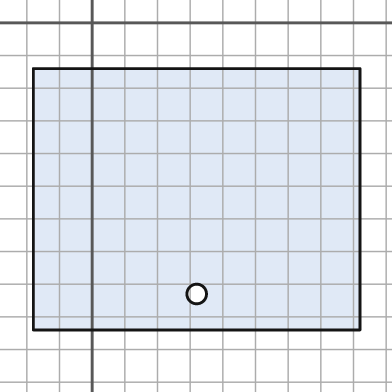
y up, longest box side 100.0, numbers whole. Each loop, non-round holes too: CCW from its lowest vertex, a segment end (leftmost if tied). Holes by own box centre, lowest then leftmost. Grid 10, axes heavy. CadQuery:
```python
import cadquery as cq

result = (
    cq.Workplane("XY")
    .moveTo(-18.0, -94.0)
    .lineTo(82.0, -94.0)
    .lineTo(82.0, -14.0)
    .lineTo(-18.0, -14.0)
    .close()
    .moveTo(32.0, -83.0)
    .circle(3.0)
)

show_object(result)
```